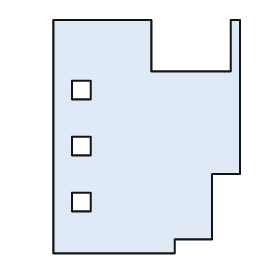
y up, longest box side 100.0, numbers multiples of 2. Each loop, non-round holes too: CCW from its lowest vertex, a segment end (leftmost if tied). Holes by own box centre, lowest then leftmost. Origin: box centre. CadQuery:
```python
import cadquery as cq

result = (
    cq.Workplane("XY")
    .moveTo(-40.0, -50.0)
    .lineTo(12.0, -50.0)
    .lineTo(12.0, -44.0)
    .lineTo(28.0, -44.0)
    .lineTo(28.0, -16.0)
    .lineTo(40.0, -16.0)
    .lineTo(40.0, 50.0)
    .lineTo(36.0, 50.0)
    .lineTo(36.0, 28.0)
    .lineTo(2.0, 28.0)
    .lineTo(2.0, 50.0)
    .lineTo(-40.0, 50.0)
    .close()
    .moveTo(-32.0, -32.0)
    .lineTo(-24.0, -32.0)
    .lineTo(-24.0, -24.0)
    .lineTo(-32.0, -24.0)
    .close()
    .moveTo(-32.0, -8.0)
    .lineTo(-24.0, -8.0)
    .lineTo(-24.0, 0.0)
    .lineTo(-32.0, 0.0)
    .close()
    .moveTo(-32.0, 16.0)
    .lineTo(-24.0, 16.0)
    .lineTo(-24.0, 24.0)
    .lineTo(-32.0, 24.0)
    .close()
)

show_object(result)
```